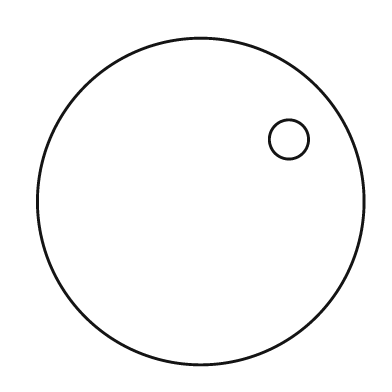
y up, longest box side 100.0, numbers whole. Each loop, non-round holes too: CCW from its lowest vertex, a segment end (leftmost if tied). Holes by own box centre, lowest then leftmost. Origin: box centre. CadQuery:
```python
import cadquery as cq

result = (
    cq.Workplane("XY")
    .moveTo(0.0, 0.0)
    .circle(50.0)
    .moveTo(27.0, 19.0)
    .circle(6.0)
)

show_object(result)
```